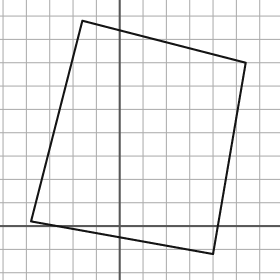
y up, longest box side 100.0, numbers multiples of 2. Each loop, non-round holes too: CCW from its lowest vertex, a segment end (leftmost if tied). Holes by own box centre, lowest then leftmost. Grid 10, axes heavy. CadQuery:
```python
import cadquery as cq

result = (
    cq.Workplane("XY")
    .moveTo(40.0, -12.0)
    .lineTo(54.0, 70.0)
    .lineTo(-16.0, 88.0)
    .lineTo(-38.0, 2.0)
    .close()
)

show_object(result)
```